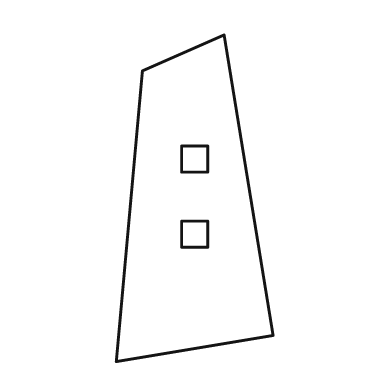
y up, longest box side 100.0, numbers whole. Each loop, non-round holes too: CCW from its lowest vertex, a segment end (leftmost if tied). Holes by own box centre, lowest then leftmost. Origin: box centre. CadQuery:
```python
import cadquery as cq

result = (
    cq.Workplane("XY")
    .moveTo(-24.0, -50.0)
    .lineTo(24.0, -42.0)
    .lineTo(9.0, 50.0)
    .lineTo(-16.0, 39.0)
    .close()
    .moveTo(-4.0, -15.0)
    .lineTo(4.0, -15.0)
    .lineTo(4.0, -7.0)
    .lineTo(-4.0, -7.0)
    .close()
    .moveTo(-4.0, 8.0)
    .lineTo(4.0, 8.0)
    .lineTo(4.0, 16.0)
    .lineTo(-4.0, 16.0)
    .close()
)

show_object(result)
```